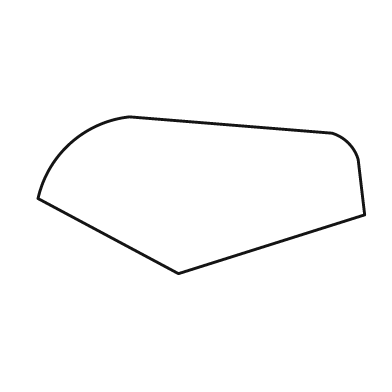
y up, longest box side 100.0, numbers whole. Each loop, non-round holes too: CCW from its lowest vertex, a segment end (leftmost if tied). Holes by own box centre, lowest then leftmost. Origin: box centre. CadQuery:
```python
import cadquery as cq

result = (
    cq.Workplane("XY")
    .moveTo(-7.0, -24.0)
    .lineTo(50.0, -6.0)
    .lineTo(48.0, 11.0)
    .threePointArc((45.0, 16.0), (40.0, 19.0))
    .lineTo(-22.0, 24.0)
    .threePointArc((-40.0, 16.0), (-50.0, -1.0))
    .close()
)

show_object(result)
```